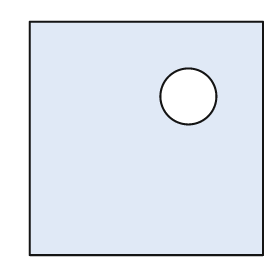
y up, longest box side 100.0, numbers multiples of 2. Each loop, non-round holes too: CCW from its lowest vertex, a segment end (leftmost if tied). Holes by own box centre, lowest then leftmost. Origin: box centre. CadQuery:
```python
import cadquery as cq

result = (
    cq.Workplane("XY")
    .moveTo(-50.0, -50.0)
    .lineTo(50.0, -50.0)
    .lineTo(50.0, 50.0)
    .lineTo(-50.0, 50.0)
    .close()
    .moveTo(18.0, 18.0)
    .circle(12.0)
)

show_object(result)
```